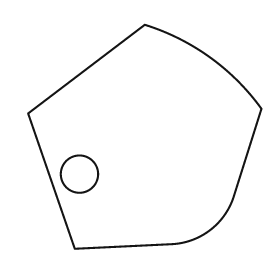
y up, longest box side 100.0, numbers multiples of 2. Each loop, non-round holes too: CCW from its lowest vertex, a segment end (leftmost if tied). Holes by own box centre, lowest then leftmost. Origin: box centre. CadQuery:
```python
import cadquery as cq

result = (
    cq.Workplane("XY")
    .moveTo(-30.0, -48.0)
    .lineTo(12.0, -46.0)
    .threePointArc((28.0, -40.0), (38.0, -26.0))
    .lineTo(50.0, 12.0)
    .threePointArc((28.0, 34.0), (0.0, 48.0))
    .lineTo(-50.0, 10.0)
    .close()
    .moveTo(-28.0, -16.0)
    .circle(8.0)
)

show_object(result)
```